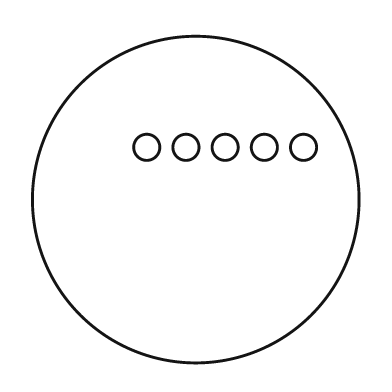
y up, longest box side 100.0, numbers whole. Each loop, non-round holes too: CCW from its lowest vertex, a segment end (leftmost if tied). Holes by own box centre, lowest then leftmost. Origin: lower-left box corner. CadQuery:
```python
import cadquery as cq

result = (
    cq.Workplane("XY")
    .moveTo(50.0, 50.0)
    .circle(50.0)
    .moveTo(35.0, 66.0)
    .circle(4.0)
    .moveTo(47.0, 66.0)
    .circle(4.0)
    .moveTo(59.0, 66.0)
    .circle(4.0)
    .moveTo(71.0, 66.0)
    .circle(4.0)
    .moveTo(83.0, 66.0)
    .circle(4.0)
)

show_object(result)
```